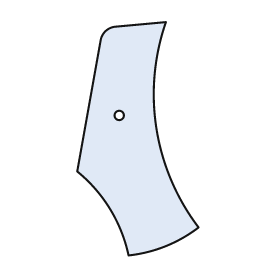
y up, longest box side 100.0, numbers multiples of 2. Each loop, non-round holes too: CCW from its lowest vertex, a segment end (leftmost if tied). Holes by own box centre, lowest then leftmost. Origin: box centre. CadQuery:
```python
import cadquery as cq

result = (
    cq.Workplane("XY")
    .moveTo(-4.0, -50.0)
    .threePointArc((12.0, -46.0), (26.0, -38.0))
    .threePointArc((8.0, 4.0), (12.0, 50.0))
    .lineTo(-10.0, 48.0)
    .threePointArc((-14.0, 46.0), (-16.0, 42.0))
    .lineTo(-26.0, -14.0)
    .threePointArc((-12.0, -30.0), (-4.0, -50.0))
    .close()
    .moveTo(-8.0, 10.0)
    .circle(2.0)
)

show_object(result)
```